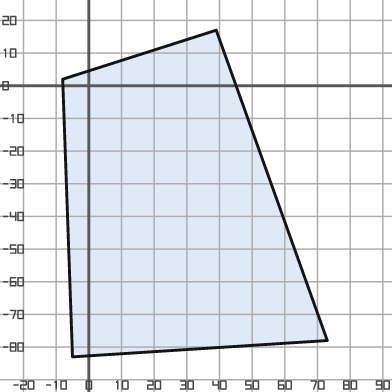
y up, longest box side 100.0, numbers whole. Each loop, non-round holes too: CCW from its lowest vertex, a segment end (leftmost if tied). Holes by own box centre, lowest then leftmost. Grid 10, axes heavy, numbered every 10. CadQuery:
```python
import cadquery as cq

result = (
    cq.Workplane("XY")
    .moveTo(-5.0, -83.0)
    .lineTo(73.0, -78.0)
    .lineTo(39.0, 17.0)
    .lineTo(-8.0, 2.0)
    .close()
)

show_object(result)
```